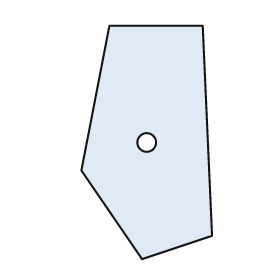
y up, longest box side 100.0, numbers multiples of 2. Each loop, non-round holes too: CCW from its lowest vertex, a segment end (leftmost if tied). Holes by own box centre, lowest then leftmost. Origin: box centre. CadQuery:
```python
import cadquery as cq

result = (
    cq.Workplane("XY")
    .moveTo(-2.0, -50.0)
    .lineTo(28.0, -40.0)
    .lineTo(24.0, 50.0)
    .lineTo(-16.0, 50.0)
    .lineTo(-28.0, -12.0)
    .close()
    .moveTo(0.0, 0.0)
    .circle(4.0)
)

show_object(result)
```